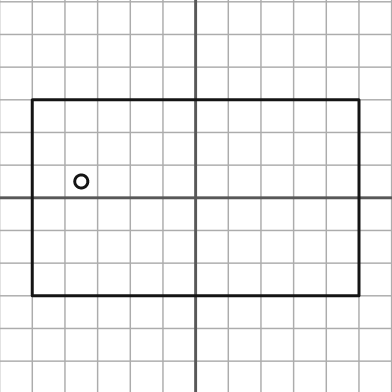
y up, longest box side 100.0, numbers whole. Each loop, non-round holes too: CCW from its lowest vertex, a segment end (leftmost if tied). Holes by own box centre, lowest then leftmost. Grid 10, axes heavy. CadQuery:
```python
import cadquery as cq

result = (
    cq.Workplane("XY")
    .moveTo(-50.0, -30.0)
    .lineTo(50.0, -30.0)
    .lineTo(50.0, 30.0)
    .lineTo(-50.0, 30.0)
    .close()
    .moveTo(-35.0, 5.0)
    .circle(2.0)
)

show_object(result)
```